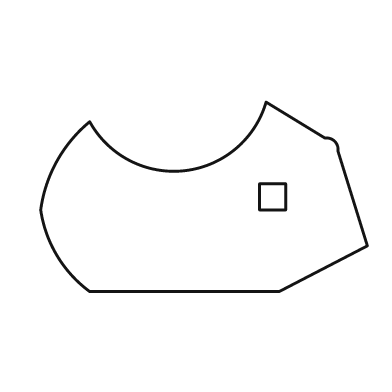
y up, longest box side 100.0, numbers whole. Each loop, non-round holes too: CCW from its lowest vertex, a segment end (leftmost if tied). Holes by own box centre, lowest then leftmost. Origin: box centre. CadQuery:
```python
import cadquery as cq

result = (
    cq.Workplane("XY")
    .moveTo(-35.0, -29.0)
    .lineTo(23.0, -29.0)
    .lineTo(50.0, -15.0)
    .lineTo(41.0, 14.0)
    .threePointArc((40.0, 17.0), (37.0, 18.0))
    .lineTo(19.0, 29.0)
    .threePointArc((-6.0, 8.0), (-35.0, 23.0))
    .threePointArc((-45.0, 11.0), (-50.0, -4.0))
    .threePointArc((-45.0, -18.0), (-35.0, -29.0))
    .close()
    .moveTo(17.0, -4.0)
    .lineTo(25.0, -4.0)
    .lineTo(25.0, 4.0)
    .lineTo(17.0, 4.0)
    .close()
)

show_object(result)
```